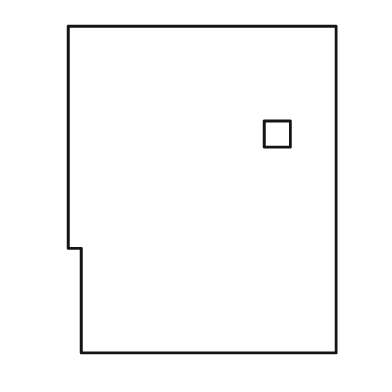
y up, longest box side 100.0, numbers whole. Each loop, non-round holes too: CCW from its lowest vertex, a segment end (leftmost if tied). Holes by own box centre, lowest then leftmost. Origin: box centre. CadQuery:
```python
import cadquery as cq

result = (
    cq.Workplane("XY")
    .moveTo(-37.0, -50.0)
    .lineTo(41.0, -50.0)
    .lineTo(41.0, 50.0)
    .lineTo(-41.0, 50.0)
    .lineTo(-41.0, -18.0)
    .lineTo(-37.0, -18.0)
    .close()
    .moveTo(19.0, 13.0)
    .lineTo(27.0, 13.0)
    .lineTo(27.0, 21.0)
    .lineTo(19.0, 21.0)
    .close()
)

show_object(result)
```